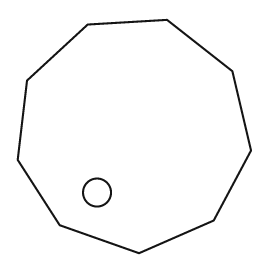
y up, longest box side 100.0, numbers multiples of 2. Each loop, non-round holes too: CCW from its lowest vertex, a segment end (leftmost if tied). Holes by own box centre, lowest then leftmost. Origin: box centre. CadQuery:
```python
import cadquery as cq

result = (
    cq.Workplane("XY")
    .moveTo(2.0, -50.0)
    .lineTo(34.0, -36.0)
    .lineTo(50.0, -6.0)
    .lineTo(42.0, 28.0)
    .lineTo(14.0, 50.0)
    .lineTo(-20.0, 48.0)
    .lineTo(-46.0, 24.0)
    .lineTo(-50.0, -10.0)
    .lineTo(-32.0, -38.0)
    .close()
    .moveTo(-16.0, -24.0)
    .circle(6.0)
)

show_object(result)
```